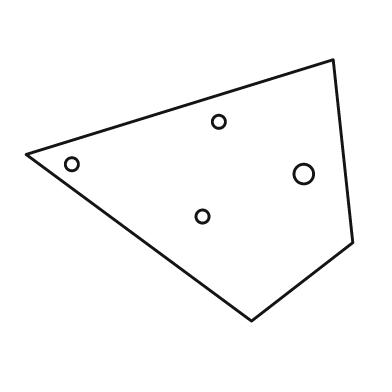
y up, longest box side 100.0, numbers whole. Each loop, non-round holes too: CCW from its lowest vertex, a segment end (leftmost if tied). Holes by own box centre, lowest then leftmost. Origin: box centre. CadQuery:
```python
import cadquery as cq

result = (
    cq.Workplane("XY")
    .moveTo(19.0, -40.0)
    .lineTo(50.0, -16.0)
    .lineTo(44.0, 40.0)
    .lineTo(-50.0, 11.0)
    .close()
    .moveTo(4.0, -8.0)
    .circle(2.0)
    .moveTo(35.0, 5.0)
    .circle(3.0)
    .moveTo(-36.0, 8.0)
    .circle(2.0)
    .moveTo(9.0, 21.0)
    .circle(2.0)
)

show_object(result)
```